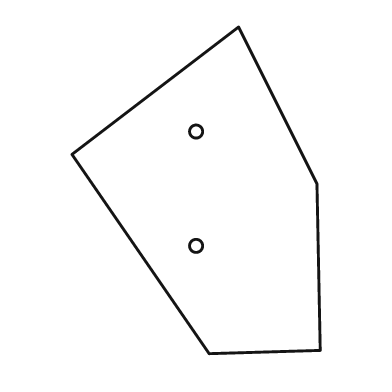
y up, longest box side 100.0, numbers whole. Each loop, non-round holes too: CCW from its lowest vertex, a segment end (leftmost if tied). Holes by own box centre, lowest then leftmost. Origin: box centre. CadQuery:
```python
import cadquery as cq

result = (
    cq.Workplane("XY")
    .moveTo(4.0, -50.0)
    .lineTo(38.0, -49.0)
    .lineTo(37.0, 2.0)
    .lineTo(13.0, 50.0)
    .lineTo(-38.0, 11.0)
    .close()
    .moveTo(0.0, -17.0)
    .circle(2.0)
    .moveTo(0.0, 18.0)
    .circle(2.0)
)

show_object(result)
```